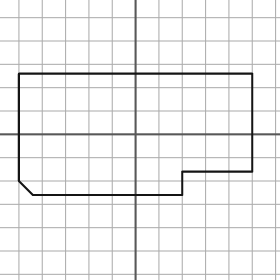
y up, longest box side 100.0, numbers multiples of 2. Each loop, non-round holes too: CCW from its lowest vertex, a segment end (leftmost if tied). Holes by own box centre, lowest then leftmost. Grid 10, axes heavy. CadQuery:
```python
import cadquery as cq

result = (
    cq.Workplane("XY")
    .moveTo(-44.0, -26.0)
    .lineTo(20.0, -26.0)
    .lineTo(20.0, -16.0)
    .lineTo(50.0, -16.0)
    .lineTo(50.0, 26.0)
    .lineTo(-50.0, 26.0)
    .lineTo(-50.0, -20.0)
    .close()
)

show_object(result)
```